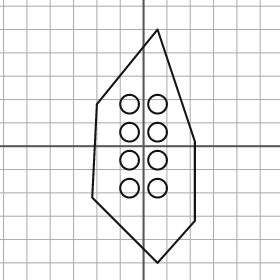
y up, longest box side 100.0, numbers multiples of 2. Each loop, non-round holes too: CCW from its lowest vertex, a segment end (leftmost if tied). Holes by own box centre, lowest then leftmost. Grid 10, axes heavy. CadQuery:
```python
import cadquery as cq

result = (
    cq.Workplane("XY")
    .moveTo(6.0, -50.0)
    .lineTo(22.0, -32.0)
    .lineTo(22.0, 2.0)
    .lineTo(6.0, 50.0)
    .lineTo(-20.0, 18.0)
    .lineTo(-22.0, -22.0)
    .close()
    .moveTo(-6.0, -18.0)
    .circle(4.0)
    .moveTo(6.0, -18.0)
    .circle(4.0)
    .moveTo(-6.0, -6.0)
    .circle(4.0)
    .moveTo(6.0, -6.0)
    .circle(4.0)
    .moveTo(-6.0, 6.0)
    .circle(4.0)
    .moveTo(6.0, 6.0)
    .circle(4.0)
    .moveTo(-6.0, 18.0)
    .circle(4.0)
    .moveTo(6.0, 18.0)
    .circle(4.0)
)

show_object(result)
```